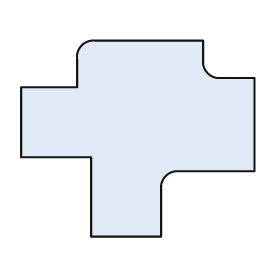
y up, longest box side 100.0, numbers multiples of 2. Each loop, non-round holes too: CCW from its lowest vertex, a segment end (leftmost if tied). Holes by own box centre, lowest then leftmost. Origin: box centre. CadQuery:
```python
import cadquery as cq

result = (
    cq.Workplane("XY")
    .moveTo(-20.0, -42.0)
    .lineTo(10.0, -42.0)
    .lineTo(10.0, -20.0)
    .threePointArc((12.0, -16.0), (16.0, -14.0))
    .lineTo(50.0, -14.0)
    .lineTo(50.0, 26.0)
    .lineTo(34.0, 26.0)
    .threePointArc((30.0, 28.0), (28.0, 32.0))
    .lineTo(28.0, 42.0)
    .lineTo(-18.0, 42.0)
    .threePointArc((-24.0, 40.0), (-26.0, 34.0))
    .lineTo(-26.0, 22.0)
    .lineTo(-50.0, 22.0)
    .lineTo(-50.0, -8.0)
    .lineTo(-20.0, -8.0)
    .close()
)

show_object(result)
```